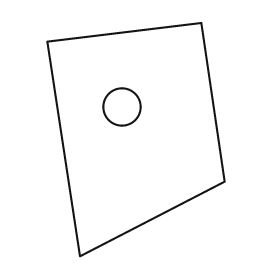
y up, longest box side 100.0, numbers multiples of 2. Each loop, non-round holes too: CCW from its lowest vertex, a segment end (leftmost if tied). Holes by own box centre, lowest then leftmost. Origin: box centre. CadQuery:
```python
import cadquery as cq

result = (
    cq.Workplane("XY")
    .moveTo(-24.0, -50.0)
    .lineTo(38.0, -18.0)
    .lineTo(28.0, 50.0)
    .lineTo(-38.0, 42.0)
    .close()
    .moveTo(-6.0, 14.0)
    .circle(8.0)
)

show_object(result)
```